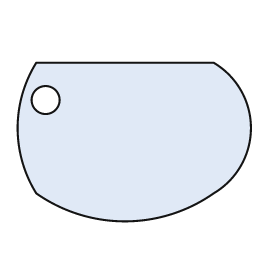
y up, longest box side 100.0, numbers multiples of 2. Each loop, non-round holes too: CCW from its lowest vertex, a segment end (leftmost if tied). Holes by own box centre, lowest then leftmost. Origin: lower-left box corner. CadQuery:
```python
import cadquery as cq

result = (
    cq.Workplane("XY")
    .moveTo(8.0, 12.0)
    .threePointArc((46.0, 0.0), (84.0, 12.0))
    .threePointArc((100.0, 40.0), (84.0, 68.0))
    .lineTo(8.0, 68.0)
    .threePointArc((0.0, 40.0), (8.0, 12.0))
    .close()
    .moveTo(12.0, 52.0)
    .circle(6.0)
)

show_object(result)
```